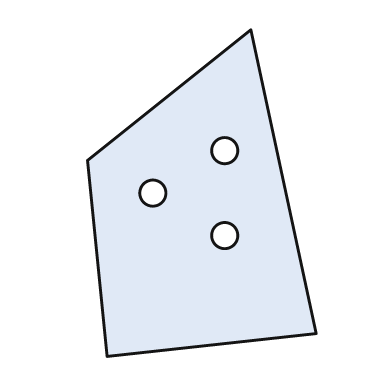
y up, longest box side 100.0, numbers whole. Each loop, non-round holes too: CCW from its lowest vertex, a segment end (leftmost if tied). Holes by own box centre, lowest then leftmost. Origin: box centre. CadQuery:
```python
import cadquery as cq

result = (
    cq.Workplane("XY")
    .moveTo(-29.0, -50.0)
    .lineTo(35.0, -43.0)
    .lineTo(15.0, 50.0)
    .lineTo(-35.0, 10.0)
    .close()
    .moveTo(7.0, -13.0)
    .circle(4.0)
    .moveTo(-15.0, 0.0)
    .circle(4.0)
    .moveTo(7.0, 13.0)
    .circle(4.0)
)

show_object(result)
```